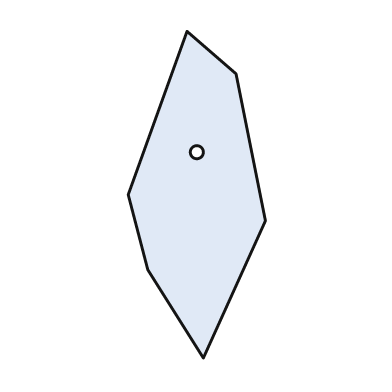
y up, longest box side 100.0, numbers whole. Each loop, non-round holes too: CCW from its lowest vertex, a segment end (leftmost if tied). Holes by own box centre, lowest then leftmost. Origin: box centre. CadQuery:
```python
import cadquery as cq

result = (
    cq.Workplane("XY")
    .moveTo(2.0, -50.0)
    .lineTo(21.0, -8.0)
    .lineTo(12.0, 37.0)
    .lineTo(-3.0, 50.0)
    .lineTo(-21.0, 0.0)
    .lineTo(-15.0, -23.0)
    .close()
    .moveTo(0.0, 13.0)
    .circle(2.0)
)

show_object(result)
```